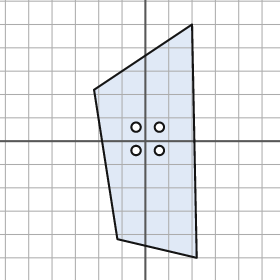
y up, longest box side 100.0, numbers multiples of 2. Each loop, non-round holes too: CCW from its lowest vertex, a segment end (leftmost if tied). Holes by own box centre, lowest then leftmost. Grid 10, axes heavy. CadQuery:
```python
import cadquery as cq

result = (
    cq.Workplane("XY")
    .moveTo(22.0, -50.0)
    .lineTo(20.0, 50.0)
    .lineTo(-22.0, 22.0)
    .lineTo(-12.0, -42.0)
    .close()
    .moveTo(-4.0, -4.0)
    .circle(2.0)
    .moveTo(6.0, -4.0)
    .circle(2.0)
    .moveTo(-4.0, 6.0)
    .circle(2.0)
    .moveTo(6.0, 6.0)
    .circle(2.0)
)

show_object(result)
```